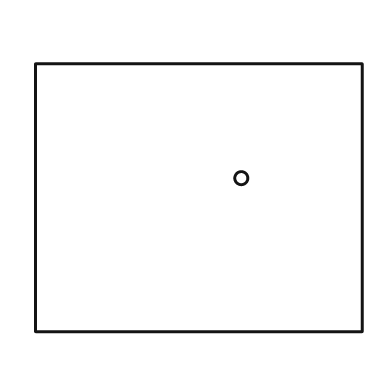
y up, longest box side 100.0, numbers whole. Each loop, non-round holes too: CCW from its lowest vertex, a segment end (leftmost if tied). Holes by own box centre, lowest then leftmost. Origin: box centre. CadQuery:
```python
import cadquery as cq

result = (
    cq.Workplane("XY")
    .moveTo(-50.0, -41.0)
    .lineTo(50.0, -41.0)
    .lineTo(50.0, 41.0)
    .lineTo(-50.0, 41.0)
    .close()
    .moveTo(13.0, 6.0)
    .circle(2.0)
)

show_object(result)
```